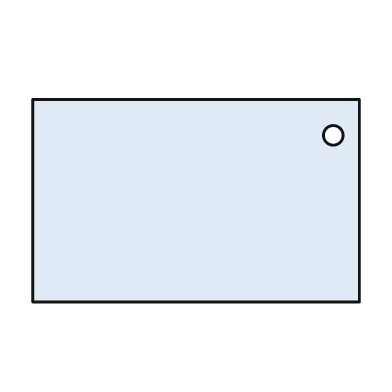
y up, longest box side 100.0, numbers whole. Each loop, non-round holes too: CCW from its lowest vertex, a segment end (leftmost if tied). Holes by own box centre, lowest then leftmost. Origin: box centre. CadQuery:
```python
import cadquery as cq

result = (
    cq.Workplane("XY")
    .moveTo(-50.0, -31.0)
    .lineTo(50.0, -31.0)
    .lineTo(50.0, 31.0)
    .lineTo(-50.0, 31.0)
    .close()
    .moveTo(42.0, 20.0)
    .circle(3.0)
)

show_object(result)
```